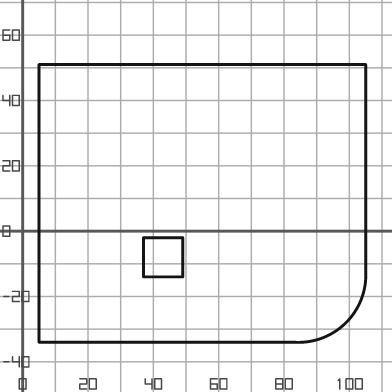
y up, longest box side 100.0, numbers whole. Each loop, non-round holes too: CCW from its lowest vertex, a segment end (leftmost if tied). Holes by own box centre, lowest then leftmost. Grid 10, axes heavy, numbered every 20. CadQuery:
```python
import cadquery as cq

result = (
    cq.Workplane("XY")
    .moveTo(5.0, -34.0)
    .lineTo(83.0, -34.0)
    .threePointArc((99.0, -28.0), (105.0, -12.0))
    .lineTo(105.0, 51.0)
    .lineTo(5.0, 51.0)
    .close()
    .moveTo(37.0, -14.0)
    .lineTo(49.0, -14.0)
    .lineTo(49.0, -2.0)
    .lineTo(37.0, -2.0)
    .close()
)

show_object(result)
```